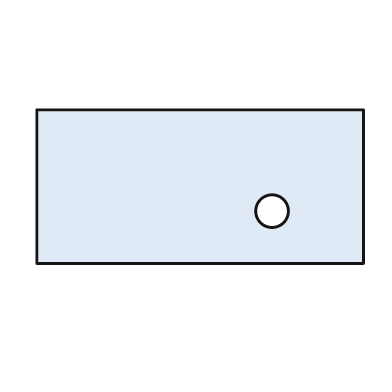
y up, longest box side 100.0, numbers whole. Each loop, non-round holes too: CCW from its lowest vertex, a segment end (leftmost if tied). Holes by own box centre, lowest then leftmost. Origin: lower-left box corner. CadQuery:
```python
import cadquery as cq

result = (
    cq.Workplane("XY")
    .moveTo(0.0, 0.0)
    .lineTo(100.0, 0.0)
    .lineTo(100.0, 47.0)
    .lineTo(0.0, 47.0)
    .close()
    .moveTo(72.0, 16.0)
    .circle(5.0)
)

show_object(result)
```